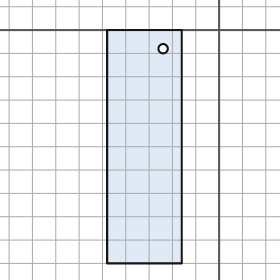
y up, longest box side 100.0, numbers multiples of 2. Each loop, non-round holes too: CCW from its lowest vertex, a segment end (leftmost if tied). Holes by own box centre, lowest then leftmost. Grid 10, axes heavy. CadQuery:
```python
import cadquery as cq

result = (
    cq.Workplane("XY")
    .moveTo(-48.0, -100.0)
    .lineTo(-16.0, -100.0)
    .lineTo(-16.0, 0.0)
    .lineTo(-48.0, 0.0)
    .close()
    .moveTo(-24.0, -8.0)
    .circle(2.0)
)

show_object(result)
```